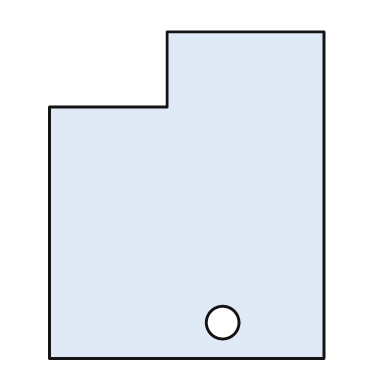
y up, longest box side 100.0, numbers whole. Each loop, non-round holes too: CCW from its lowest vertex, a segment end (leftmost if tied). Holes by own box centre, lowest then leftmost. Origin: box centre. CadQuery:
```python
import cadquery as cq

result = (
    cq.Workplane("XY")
    .moveTo(-42.0, -50.0)
    .lineTo(42.0, -50.0)
    .lineTo(42.0, 50.0)
    .lineTo(-6.0, 50.0)
    .lineTo(-6.0, 27.0)
    .lineTo(-42.0, 27.0)
    .close()
    .moveTo(11.0, -39.0)
    .circle(5.0)
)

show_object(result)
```